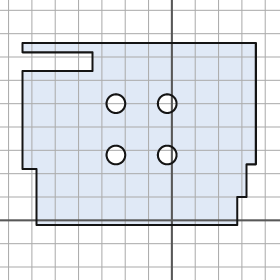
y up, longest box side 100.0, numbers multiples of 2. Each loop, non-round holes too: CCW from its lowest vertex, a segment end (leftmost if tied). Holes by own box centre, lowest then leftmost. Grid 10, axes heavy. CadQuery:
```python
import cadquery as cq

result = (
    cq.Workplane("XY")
    .moveTo(-58.0, -2.0)
    .lineTo(28.0, -2.0)
    .lineTo(28.0, 10.0)
    .lineTo(32.0, 10.0)
    .lineTo(32.0, 24.0)
    .lineTo(36.0, 24.0)
    .lineTo(36.0, 76.0)
    .lineTo(-64.0, 76.0)
    .lineTo(-64.0, 72.0)
    .lineTo(-34.0, 72.0)
    .lineTo(-34.0, 64.0)
    .lineTo(-64.0, 64.0)
    .lineTo(-64.0, 22.0)
    .lineTo(-58.0, 22.0)
    .close()
    .moveTo(-24.0, 28.0)
    .circle(4.0)
    .moveTo(-2.0, 28.0)
    .circle(4.0)
    .moveTo(-24.0, 50.0)
    .circle(4.0)
    .moveTo(-2.0, 50.0)
    .circle(4.0)
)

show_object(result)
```